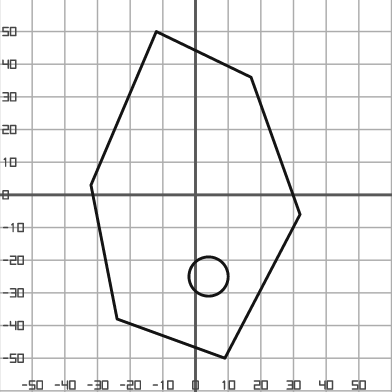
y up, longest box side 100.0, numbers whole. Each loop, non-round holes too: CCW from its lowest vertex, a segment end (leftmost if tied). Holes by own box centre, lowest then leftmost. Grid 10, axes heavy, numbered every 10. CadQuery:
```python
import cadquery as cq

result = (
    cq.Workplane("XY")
    .moveTo(9.0, -50.0)
    .lineTo(32.0, -6.0)
    .lineTo(17.0, 36.0)
    .lineTo(-12.0, 50.0)
    .lineTo(-32.0, 3.0)
    .lineTo(-24.0, -38.0)
    .close()
    .moveTo(4.0, -25.0)
    .circle(6.0)
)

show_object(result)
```